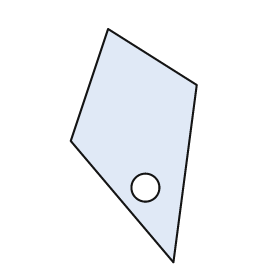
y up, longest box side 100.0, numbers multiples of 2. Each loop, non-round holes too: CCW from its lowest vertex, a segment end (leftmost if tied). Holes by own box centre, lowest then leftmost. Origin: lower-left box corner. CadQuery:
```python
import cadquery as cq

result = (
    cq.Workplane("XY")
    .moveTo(44.0, 0.0)
    .lineTo(54.0, 76.0)
    .lineTo(16.0, 100.0)
    .lineTo(0.0, 52.0)
    .close()
    .moveTo(32.0, 32.0)
    .circle(6.0)
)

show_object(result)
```